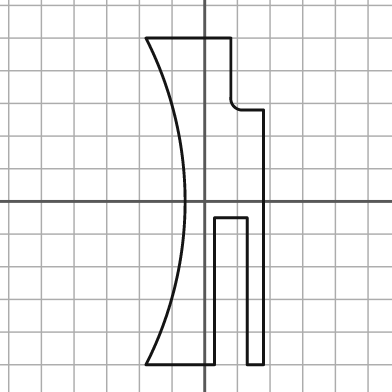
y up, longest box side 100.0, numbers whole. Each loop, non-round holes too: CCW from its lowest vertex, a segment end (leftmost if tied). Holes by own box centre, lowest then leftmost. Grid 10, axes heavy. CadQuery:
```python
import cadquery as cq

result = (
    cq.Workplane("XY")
    .moveTo(-18.0, -50.0)
    .lineTo(3.0, -50.0)
    .lineTo(3.0, -5.0)
    .lineTo(13.0, -5.0)
    .lineTo(13.0, -50.0)
    .lineTo(18.0, -50.0)
    .lineTo(18.0, 28.0)
    .lineTo(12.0, 28.0)
    .threePointArc((9.0, 29.0), (8.0, 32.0))
    .lineTo(8.0, 50.0)
    .lineTo(-18.0, 50.0)
    .threePointArc((-6.0, 0.0), (-18.0, -50.0))
    .close()
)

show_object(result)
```